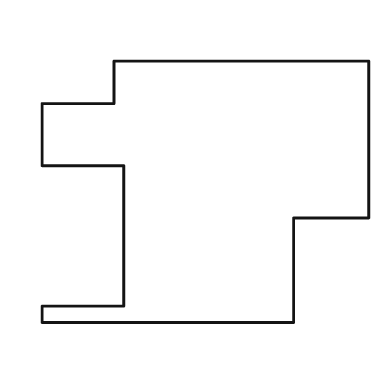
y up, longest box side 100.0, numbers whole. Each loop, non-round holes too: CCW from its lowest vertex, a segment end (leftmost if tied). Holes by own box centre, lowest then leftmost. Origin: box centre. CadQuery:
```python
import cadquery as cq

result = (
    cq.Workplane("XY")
    .moveTo(-50.0, -40.0)
    .lineTo(27.0, -40.0)
    .lineTo(27.0, -8.0)
    .lineTo(50.0, -8.0)
    .lineTo(50.0, 40.0)
    .lineTo(-28.0, 40.0)
    .lineTo(-28.0, 27.0)
    .lineTo(-50.0, 27.0)
    .lineTo(-50.0, 8.0)
    .lineTo(-25.0, 8.0)
    .lineTo(-25.0, -35.0)
    .lineTo(-50.0, -35.0)
    .close()
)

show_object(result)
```